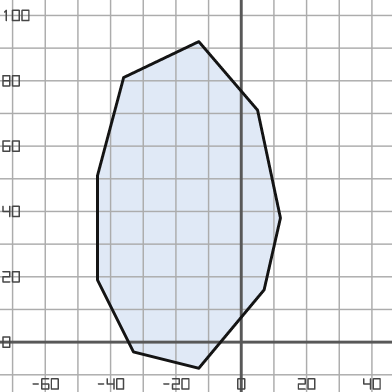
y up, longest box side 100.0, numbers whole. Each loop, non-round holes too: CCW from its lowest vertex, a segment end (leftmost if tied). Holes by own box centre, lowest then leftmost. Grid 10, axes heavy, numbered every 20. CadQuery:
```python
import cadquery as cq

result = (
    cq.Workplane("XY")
    .moveTo(-13.0, -8.0)
    .lineTo(7.0, 16.0)
    .lineTo(12.0, 38.0)
    .lineTo(5.0, 71.0)
    .lineTo(-13.0, 92.0)
    .lineTo(-36.0, 81.0)
    .lineTo(-44.0, 51.0)
    .lineTo(-44.0, 19.0)
    .lineTo(-33.0, -3.0)
    .close()
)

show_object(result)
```